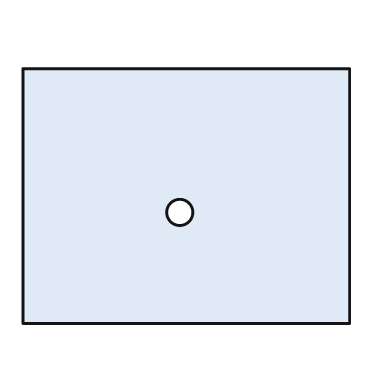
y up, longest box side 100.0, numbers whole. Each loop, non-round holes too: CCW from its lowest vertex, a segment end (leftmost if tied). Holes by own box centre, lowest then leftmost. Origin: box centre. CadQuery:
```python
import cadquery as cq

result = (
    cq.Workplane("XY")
    .moveTo(-50.0, -39.0)
    .lineTo(50.0, -39.0)
    .lineTo(50.0, 39.0)
    .lineTo(-50.0, 39.0)
    .close()
    .moveTo(-2.0, -5.0)
    .circle(4.0)
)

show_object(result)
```